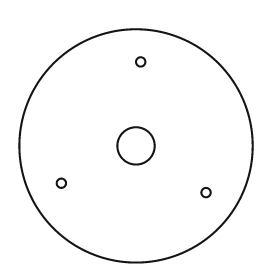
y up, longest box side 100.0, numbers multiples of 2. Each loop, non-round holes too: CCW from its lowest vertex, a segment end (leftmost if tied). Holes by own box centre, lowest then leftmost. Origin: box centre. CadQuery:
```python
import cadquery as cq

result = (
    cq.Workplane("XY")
    .moveTo(0.0, 0.0)
    .circle(50.0)
    .moveTo(30.0, -20.0)
    .circle(2.0)
    .moveTo(-32.0, -16.0)
    .circle(2.0)
    .moveTo(0.0, 0.0)
    .circle(8.0)
    .moveTo(2.0, 36.0)
    .circle(2.0)
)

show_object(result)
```